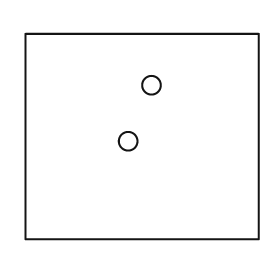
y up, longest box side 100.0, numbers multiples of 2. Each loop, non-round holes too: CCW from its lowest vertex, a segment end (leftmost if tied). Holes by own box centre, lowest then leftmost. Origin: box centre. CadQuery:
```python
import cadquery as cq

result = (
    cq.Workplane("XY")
    .moveTo(-50.0, -44.0)
    .lineTo(50.0, -44.0)
    .lineTo(50.0, 44.0)
    .lineTo(-50.0, 44.0)
    .close()
    .moveTo(-6.0, -2.0)
    .circle(4.0)
    .moveTo(4.0, 22.0)
    .circle(4.0)
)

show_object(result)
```